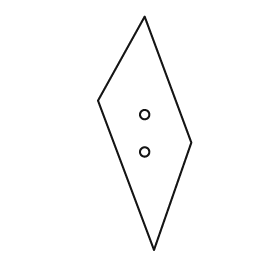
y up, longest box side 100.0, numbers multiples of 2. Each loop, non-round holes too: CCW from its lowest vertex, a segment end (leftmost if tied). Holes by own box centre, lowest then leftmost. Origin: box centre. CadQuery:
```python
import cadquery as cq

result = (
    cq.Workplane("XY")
    .moveTo(4.0, -50.0)
    .lineTo(20.0, -4.0)
    .lineTo(0.0, 50.0)
    .lineTo(-20.0, 14.0)
    .close()
    .moveTo(0.0, -8.0)
    .circle(2.0)
    .moveTo(0.0, 8.0)
    .circle(2.0)
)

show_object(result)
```